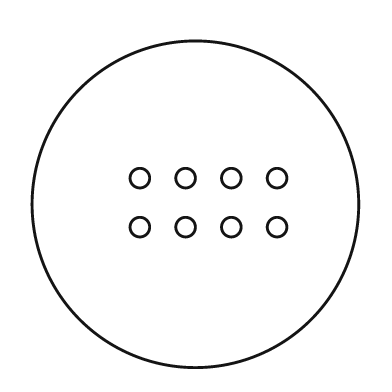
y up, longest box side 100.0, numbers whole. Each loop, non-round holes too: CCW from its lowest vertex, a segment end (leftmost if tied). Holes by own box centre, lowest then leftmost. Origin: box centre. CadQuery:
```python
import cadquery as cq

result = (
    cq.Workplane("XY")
    .moveTo(0.0, 0.0)
    .circle(50.0)
    .moveTo(-17.0, -7.0)
    .circle(3.0)
    .moveTo(-3.0, -7.0)
    .circle(3.0)
    .moveTo(11.0, -7.0)
    .circle(3.0)
    .moveTo(25.0, -7.0)
    .circle(3.0)
    .moveTo(-17.0, 8.0)
    .circle(3.0)
    .moveTo(-3.0, 8.0)
    .circle(3.0)
    .moveTo(11.0, 8.0)
    .circle(3.0)
    .moveTo(25.0, 8.0)
    .circle(3.0)
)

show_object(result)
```